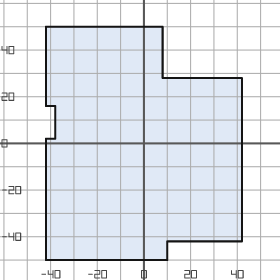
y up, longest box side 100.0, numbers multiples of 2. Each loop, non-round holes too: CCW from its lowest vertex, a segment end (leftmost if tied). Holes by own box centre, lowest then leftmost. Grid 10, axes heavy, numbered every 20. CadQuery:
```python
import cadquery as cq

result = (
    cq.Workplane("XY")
    .moveTo(-42.0, -50.0)
    .lineTo(10.0, -50.0)
    .lineTo(10.0, -42.0)
    .lineTo(42.0, -42.0)
    .lineTo(42.0, 28.0)
    .lineTo(8.0, 28.0)
    .lineTo(8.0, 50.0)
    .lineTo(-42.0, 50.0)
    .lineTo(-42.0, 16.0)
    .lineTo(-38.0, 16.0)
    .lineTo(-38.0, 2.0)
    .lineTo(-42.0, 2.0)
    .close()
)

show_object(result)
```